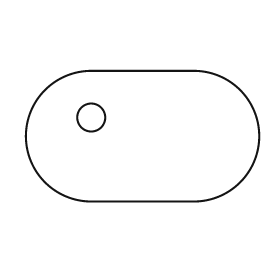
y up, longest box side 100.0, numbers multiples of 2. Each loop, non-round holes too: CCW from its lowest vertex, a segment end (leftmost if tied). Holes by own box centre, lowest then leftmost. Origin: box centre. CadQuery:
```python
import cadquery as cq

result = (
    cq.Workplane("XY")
    .moveTo(-22.0, -28.0)
    .lineTo(22.0, -28.0)
    .threePointArc((50.0, 0.0), (22.0, 28.0))
    .lineTo(-22.0, 28.0)
    .threePointArc((-50.0, 0.0), (-22.0, -28.0))
    .close()
    .moveTo(-22.0, 8.0)
    .circle(6.0)
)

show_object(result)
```